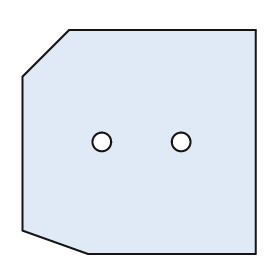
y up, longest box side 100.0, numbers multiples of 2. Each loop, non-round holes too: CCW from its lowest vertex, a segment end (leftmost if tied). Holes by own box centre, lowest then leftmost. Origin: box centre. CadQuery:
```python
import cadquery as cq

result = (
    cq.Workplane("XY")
    .moveTo(-22.0, -48.0)
    .lineTo(50.0, -48.0)
    .lineTo(50.0, 48.0)
    .lineTo(-30.0, 48.0)
    .lineTo(-50.0, 28.0)
    .lineTo(-50.0, -38.0)
    .close()
    .moveTo(-16.0, 0.0)
    .circle(4.0)
    .moveTo(18.0, 0.0)
    .circle(4.0)
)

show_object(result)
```